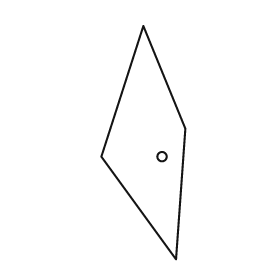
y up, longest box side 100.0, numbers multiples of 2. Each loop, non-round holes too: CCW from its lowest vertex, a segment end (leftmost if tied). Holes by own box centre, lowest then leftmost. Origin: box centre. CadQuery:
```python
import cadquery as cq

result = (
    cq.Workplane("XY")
    .moveTo(14.0, -50.0)
    .lineTo(18.0, 6.0)
    .lineTo(0.0, 50.0)
    .lineTo(-18.0, -6.0)
    .close()
    .moveTo(8.0, -6.0)
    .circle(2.0)
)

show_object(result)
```